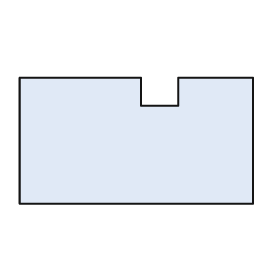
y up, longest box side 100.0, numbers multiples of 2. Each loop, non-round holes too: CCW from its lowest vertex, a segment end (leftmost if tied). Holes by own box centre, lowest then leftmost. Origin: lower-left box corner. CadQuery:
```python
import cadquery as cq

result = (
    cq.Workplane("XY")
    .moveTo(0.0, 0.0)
    .lineTo(100.0, 0.0)
    .lineTo(100.0, 54.0)
    .lineTo(68.0, 54.0)
    .lineTo(68.0, 42.0)
    .lineTo(52.0, 42.0)
    .lineTo(52.0, 54.0)
    .lineTo(0.0, 54.0)
    .close()
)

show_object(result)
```